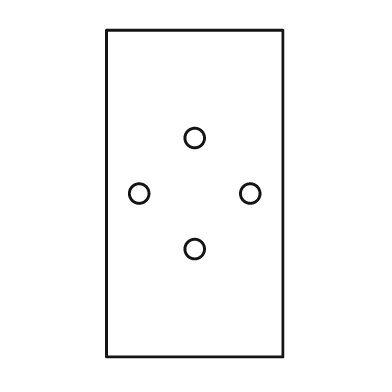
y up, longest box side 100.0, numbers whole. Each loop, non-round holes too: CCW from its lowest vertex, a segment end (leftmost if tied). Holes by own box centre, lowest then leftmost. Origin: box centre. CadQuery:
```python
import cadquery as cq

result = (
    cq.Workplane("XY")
    .moveTo(-27.0, -50.0)
    .lineTo(27.0, -50.0)
    .lineTo(27.0, 50.0)
    .lineTo(-27.0, 50.0)
    .close()
    .moveTo(0.0, -17.0)
    .circle(3.0)
    .moveTo(-17.0, 0.0)
    .circle(3.0)
    .moveTo(17.0, 0.0)
    .circle(3.0)
    .moveTo(0.0, 17.0)
    .circle(3.0)
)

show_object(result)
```